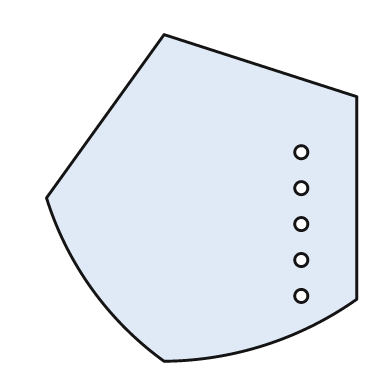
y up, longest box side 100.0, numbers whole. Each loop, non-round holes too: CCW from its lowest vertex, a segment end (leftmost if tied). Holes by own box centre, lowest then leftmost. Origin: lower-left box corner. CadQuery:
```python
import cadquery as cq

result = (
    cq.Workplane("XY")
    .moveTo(36.0, 0.0)
    .threePointArc((67.0, 5.0), (95.0, 19.0))
    .lineTo(95.0, 81.0)
    .lineTo(36.0, 100.0)
    .lineTo(0.0, 50.0)
    .threePointArc((14.0, 22.0), (36.0, 0.0))
    .close()
    .moveTo(78.0, 20.0)
    .circle(2.0)
    .moveTo(78.0, 31.0)
    .circle(2.0)
    .moveTo(78.0, 42.0)
    .circle(2.0)
    .moveTo(78.0, 53.0)
    .circle(2.0)
    .moveTo(78.0, 64.0)
    .circle(2.0)
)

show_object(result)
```